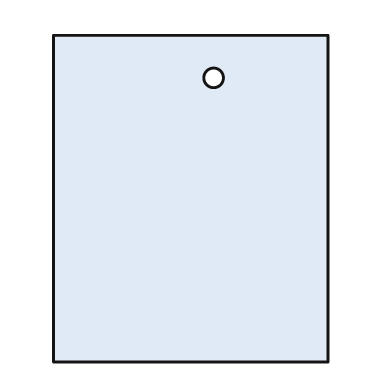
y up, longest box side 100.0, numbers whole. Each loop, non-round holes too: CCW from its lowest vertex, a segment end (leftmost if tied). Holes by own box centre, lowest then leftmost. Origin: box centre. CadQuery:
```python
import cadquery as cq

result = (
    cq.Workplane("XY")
    .moveTo(-42.0, -50.0)
    .lineTo(42.0, -50.0)
    .lineTo(42.0, 50.0)
    .lineTo(-42.0, 50.0)
    .close()
    .moveTo(7.0, 37.0)
    .circle(3.0)
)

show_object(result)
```